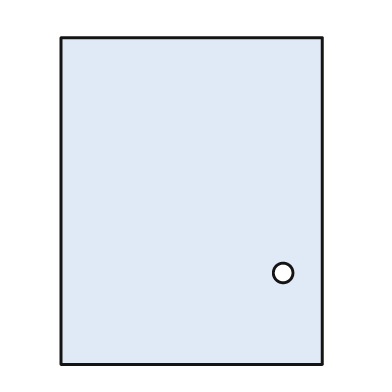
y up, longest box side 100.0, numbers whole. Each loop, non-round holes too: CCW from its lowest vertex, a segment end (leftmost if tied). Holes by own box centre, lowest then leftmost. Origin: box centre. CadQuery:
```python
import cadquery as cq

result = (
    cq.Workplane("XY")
    .moveTo(-40.0, -50.0)
    .lineTo(40.0, -50.0)
    .lineTo(40.0, 50.0)
    .lineTo(-40.0, 50.0)
    .close()
    .moveTo(28.0, -22.0)
    .circle(3.0)
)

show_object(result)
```